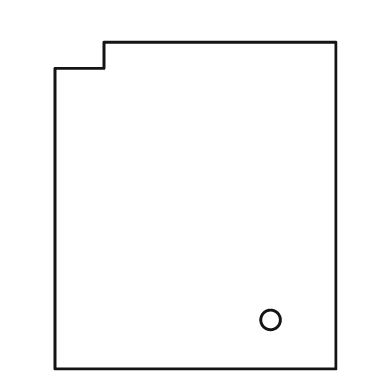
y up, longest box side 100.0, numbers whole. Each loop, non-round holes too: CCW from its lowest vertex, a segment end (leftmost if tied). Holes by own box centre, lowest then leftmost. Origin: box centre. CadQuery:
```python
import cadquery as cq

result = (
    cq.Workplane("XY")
    .moveTo(-43.0, -50.0)
    .lineTo(43.0, -50.0)
    .lineTo(43.0, 50.0)
    .lineTo(-28.0, 50.0)
    .lineTo(-28.0, 42.0)
    .lineTo(-43.0, 42.0)
    .close()
    .moveTo(23.0, -35.0)
    .circle(3.0)
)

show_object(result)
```